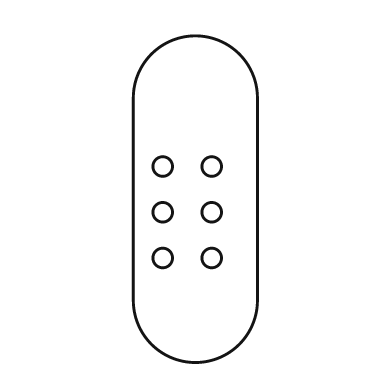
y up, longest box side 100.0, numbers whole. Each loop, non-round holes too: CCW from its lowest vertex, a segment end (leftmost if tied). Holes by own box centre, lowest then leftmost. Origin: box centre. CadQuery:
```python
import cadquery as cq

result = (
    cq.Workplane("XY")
    .moveTo(-19.0, -31.0)
    .threePointArc((0.0, -50.0), (19.0, -31.0))
    .lineTo(19.0, 31.0)
    .threePointArc((0.0, 50.0), (-19.0, 31.0))
    .close()
    .moveTo(-10.0, -18.0)
    .circle(3.0)
    .moveTo(5.0, -18.0)
    .circle(3.0)
    .moveTo(-10.0, -4.0)
    .circle(3.0)
    .moveTo(5.0, -4.0)
    .circle(3.0)
    .moveTo(-10.0, 10.0)
    .circle(3.0)
    .moveTo(5.0, 10.0)
    .circle(3.0)
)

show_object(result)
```